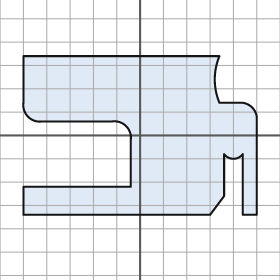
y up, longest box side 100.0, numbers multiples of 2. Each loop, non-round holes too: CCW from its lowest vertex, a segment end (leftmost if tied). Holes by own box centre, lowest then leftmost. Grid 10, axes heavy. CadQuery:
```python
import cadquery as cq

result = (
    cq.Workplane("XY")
    .moveTo(-50.0, -34.0)
    .lineTo(30.0, -34.0)
    .lineTo(36.0, -26.0)
    .lineTo(36.0, -8.0)
    .threePointArc((40.0, -10.0), (44.0, -8.0))
    .lineTo(44.0, -34.0)
    .lineTo(50.0, -34.0)
    .lineTo(50.0, 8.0)
    .threePointArc((48.0, 12.0), (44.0, 14.0))
    .lineTo(34.0, 14.0)
    .threePointArc((32.0, 24.0), (34.0, 34.0))
    .lineTo(-50.0, 34.0)
    .lineTo(-50.0, 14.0)
    .threePointArc((-48.0, 8.0), (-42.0, 6.0))
    .lineTo(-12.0, 6.0)
    .threePointArc((-6.0, 4.0), (-4.0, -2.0))
    .lineTo(-4.0, -22.0)
    .lineTo(-50.0, -22.0)
    .close()
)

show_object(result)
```